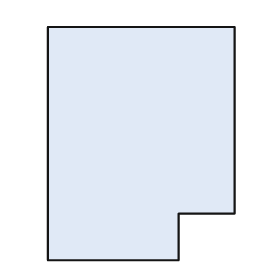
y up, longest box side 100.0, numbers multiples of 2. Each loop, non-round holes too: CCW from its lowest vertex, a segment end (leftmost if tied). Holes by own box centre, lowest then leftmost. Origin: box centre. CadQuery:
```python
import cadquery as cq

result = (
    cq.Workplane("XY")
    .moveTo(-40.0, -50.0)
    .lineTo(16.0, -50.0)
    .lineTo(16.0, -30.0)
    .lineTo(40.0, -30.0)
    .lineTo(40.0, 50.0)
    .lineTo(-40.0, 50.0)
    .close()
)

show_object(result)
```